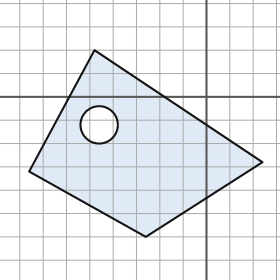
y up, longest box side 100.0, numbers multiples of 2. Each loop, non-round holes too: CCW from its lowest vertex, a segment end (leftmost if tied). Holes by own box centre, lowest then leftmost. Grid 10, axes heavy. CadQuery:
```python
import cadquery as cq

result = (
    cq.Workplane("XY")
    .moveTo(-26.0, -60.0)
    .lineTo(24.0, -28.0)
    .lineTo(-48.0, 20.0)
    .lineTo(-76.0, -32.0)
    .close()
    .moveTo(-46.0, -12.0)
    .circle(8.0)
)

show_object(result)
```